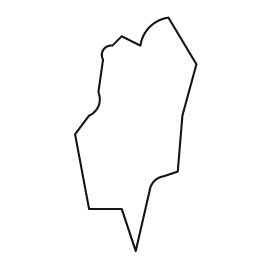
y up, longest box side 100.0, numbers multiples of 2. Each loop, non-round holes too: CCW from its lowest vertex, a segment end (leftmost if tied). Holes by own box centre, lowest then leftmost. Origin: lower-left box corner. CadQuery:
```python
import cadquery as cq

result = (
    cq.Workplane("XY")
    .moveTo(26.0, 0.0)
    .lineTo(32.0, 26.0)
    .threePointArc((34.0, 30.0), (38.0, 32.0))
    .lineTo(44.0, 34.0)
    .lineTo(46.0, 58.0)
    .lineTo(52.0, 80.0)
    .lineTo(40.0, 100.0)
    .threePointArc((32.0, 96.0), (28.0, 88.0))
    .lineTo(20.0, 92.0)
    .lineTo(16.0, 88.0)
    .threePointArc((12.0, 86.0), (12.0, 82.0))
    .lineTo(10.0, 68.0)
    .threePointArc((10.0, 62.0), (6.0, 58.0))
    .lineTo(0.0, 50.0)
    .lineTo(6.0, 18.0)
    .lineTo(20.0, 18.0)
    .close()
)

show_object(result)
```